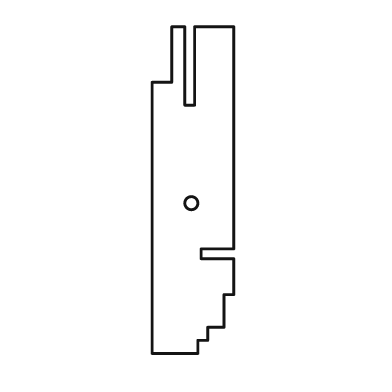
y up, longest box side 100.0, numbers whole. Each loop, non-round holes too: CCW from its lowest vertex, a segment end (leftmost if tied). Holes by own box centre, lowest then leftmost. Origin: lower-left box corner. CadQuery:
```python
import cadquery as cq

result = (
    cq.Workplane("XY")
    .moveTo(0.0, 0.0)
    .lineTo(14.0, 0.0)
    .lineTo(14.0, 4.0)
    .lineTo(17.0, 4.0)
    .lineTo(17.0, 8.0)
    .lineTo(22.0, 8.0)
    .lineTo(22.0, 18.0)
    .lineTo(25.0, 18.0)
    .lineTo(25.0, 29.0)
    .lineTo(15.0, 29.0)
    .lineTo(15.0, 32.0)
    .lineTo(25.0, 32.0)
    .lineTo(25.0, 100.0)
    .lineTo(13.0, 100.0)
    .lineTo(13.0, 76.0)
    .lineTo(10.0, 76.0)
    .lineTo(10.0, 100.0)
    .lineTo(6.0, 100.0)
    .lineTo(6.0, 83.0)
    .lineTo(0.0, 83.0)
    .close()
    .moveTo(12.0, 46.0)
    .circle(2.0)
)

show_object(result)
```